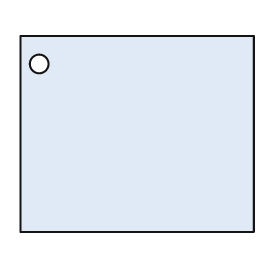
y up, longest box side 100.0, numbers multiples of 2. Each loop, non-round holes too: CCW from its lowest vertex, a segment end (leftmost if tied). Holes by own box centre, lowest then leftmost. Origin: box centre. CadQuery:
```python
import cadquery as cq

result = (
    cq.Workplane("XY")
    .moveTo(-50.0, -42.0)
    .lineTo(50.0, -42.0)
    .lineTo(50.0, 42.0)
    .lineTo(-50.0, 42.0)
    .close()
    .moveTo(-42.0, 30.0)
    .circle(4.0)
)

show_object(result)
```